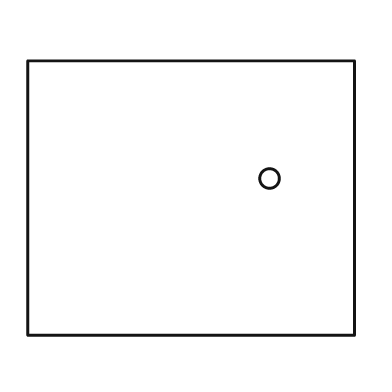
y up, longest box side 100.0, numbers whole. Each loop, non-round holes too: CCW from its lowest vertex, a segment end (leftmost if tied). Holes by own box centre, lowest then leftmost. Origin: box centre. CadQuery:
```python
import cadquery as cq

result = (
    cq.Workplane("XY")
    .moveTo(-50.0, -42.0)
    .lineTo(50.0, -42.0)
    .lineTo(50.0, 42.0)
    .lineTo(-50.0, 42.0)
    .close()
    .moveTo(24.0, 6.0)
    .circle(3.0)
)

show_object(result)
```